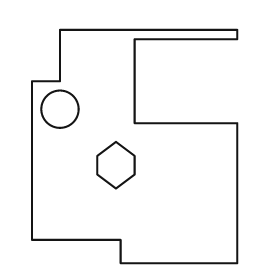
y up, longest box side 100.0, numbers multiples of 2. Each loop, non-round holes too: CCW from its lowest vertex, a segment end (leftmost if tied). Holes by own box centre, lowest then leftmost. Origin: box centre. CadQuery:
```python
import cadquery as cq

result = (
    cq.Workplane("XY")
    .moveTo(-6.0, -50.0)
    .lineTo(44.0, -50.0)
    .lineTo(44.0, 10.0)
    .lineTo(0.0, 10.0)
    .lineTo(0.0, 46.0)
    .lineTo(44.0, 46.0)
    .lineTo(44.0, 50.0)
    .lineTo(-32.0, 50.0)
    .lineTo(-32.0, 28.0)
    .lineTo(-44.0, 28.0)
    .lineTo(-44.0, -40.0)
    .lineTo(-6.0, -40.0)
    .close()
    .moveTo(-8.0, -18.0)
    .lineTo(0.0, -12.0)
    .lineTo(0.0, -4.0)
    .lineTo(-8.0, 2.0)
    .lineTo(-16.0, -4.0)
    .lineTo(-16.0, -12.0)
    .close()
    .moveTo(-32.0, 16.0)
    .circle(8.0)
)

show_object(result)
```